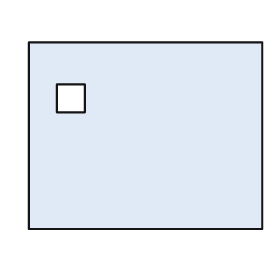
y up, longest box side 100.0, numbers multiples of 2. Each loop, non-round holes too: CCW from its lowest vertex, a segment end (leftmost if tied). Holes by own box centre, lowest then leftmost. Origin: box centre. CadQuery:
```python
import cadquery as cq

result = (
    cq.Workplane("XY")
    .moveTo(-50.0, -40.0)
    .lineTo(50.0, -40.0)
    .lineTo(50.0, 40.0)
    .lineTo(-50.0, 40.0)
    .close()
    .moveTo(-38.0, 10.0)
    .lineTo(-26.0, 10.0)
    .lineTo(-26.0, 22.0)
    .lineTo(-38.0, 22.0)
    .close()
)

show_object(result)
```